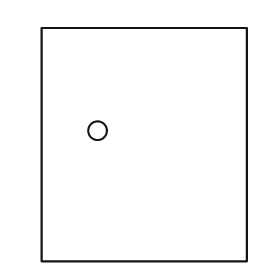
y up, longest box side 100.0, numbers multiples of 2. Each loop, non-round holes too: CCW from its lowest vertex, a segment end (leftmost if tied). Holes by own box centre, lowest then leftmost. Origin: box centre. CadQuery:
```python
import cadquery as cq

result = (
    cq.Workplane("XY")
    .moveTo(-44.0, -50.0)
    .lineTo(44.0, -50.0)
    .lineTo(44.0, 50.0)
    .lineTo(-44.0, 50.0)
    .close()
    .moveTo(-20.0, 6.0)
    .circle(4.0)
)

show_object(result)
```